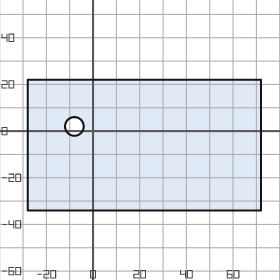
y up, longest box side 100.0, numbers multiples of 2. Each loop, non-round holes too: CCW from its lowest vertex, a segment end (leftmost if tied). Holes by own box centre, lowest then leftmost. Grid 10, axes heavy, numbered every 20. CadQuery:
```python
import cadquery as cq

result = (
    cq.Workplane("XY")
    .moveTo(-28.0, -34.0)
    .lineTo(72.0, -34.0)
    .lineTo(72.0, 22.0)
    .lineTo(-28.0, 22.0)
    .close()
    .moveTo(-8.0, 2.0)
    .circle(4.0)
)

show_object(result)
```